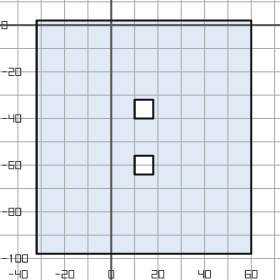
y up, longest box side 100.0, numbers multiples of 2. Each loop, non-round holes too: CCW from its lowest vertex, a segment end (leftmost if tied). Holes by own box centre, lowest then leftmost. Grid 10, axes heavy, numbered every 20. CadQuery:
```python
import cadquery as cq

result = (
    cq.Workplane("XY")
    .moveTo(-32.0, -98.0)
    .lineTo(60.0, -98.0)
    .lineTo(60.0, 2.0)
    .lineTo(-32.0, 2.0)
    .close()
    .moveTo(10.0, -64.0)
    .lineTo(18.0, -64.0)
    .lineTo(18.0, -56.0)
    .lineTo(10.0, -56.0)
    .close()
    .moveTo(10.0, -40.0)
    .lineTo(18.0, -40.0)
    .lineTo(18.0, -32.0)
    .lineTo(10.0, -32.0)
    .close()
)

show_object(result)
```